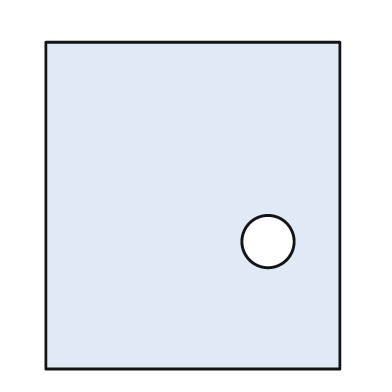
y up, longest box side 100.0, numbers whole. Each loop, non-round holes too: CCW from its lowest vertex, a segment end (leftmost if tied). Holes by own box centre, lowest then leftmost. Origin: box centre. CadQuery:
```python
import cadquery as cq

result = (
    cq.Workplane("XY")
    .moveTo(-45.0, -50.0)
    .lineTo(45.0, -50.0)
    .lineTo(45.0, 50.0)
    .lineTo(-45.0, 50.0)
    .close()
    .moveTo(23.0, -11.0)
    .circle(8.0)
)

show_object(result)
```